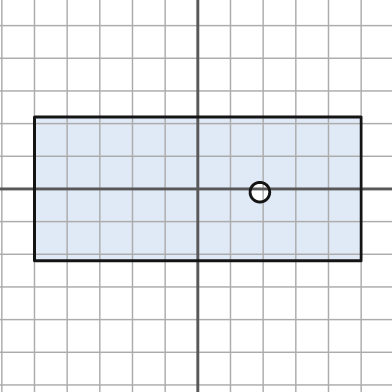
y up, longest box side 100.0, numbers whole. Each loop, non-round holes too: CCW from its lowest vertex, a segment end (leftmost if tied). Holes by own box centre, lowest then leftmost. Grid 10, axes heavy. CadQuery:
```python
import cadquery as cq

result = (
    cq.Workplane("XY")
    .moveTo(-50.0, -22.0)
    .lineTo(50.0, -22.0)
    .lineTo(50.0, 22.0)
    .lineTo(-50.0, 22.0)
    .close()
    .moveTo(19.0, -1.0)
    .circle(3.0)
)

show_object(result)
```